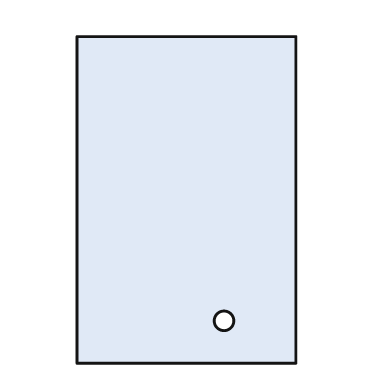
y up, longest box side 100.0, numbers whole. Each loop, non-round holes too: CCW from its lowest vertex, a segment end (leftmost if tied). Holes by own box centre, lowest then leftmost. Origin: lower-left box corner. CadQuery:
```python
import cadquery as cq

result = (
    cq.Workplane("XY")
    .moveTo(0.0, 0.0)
    .lineTo(67.0, 0.0)
    .lineTo(67.0, 100.0)
    .lineTo(0.0, 100.0)
    .close()
    .moveTo(45.0, 13.0)
    .circle(3.0)
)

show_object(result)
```